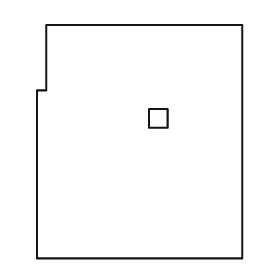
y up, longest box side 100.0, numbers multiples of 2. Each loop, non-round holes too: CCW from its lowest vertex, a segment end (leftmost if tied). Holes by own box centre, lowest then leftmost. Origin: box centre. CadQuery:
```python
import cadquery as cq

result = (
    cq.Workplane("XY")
    .moveTo(-44.0, -50.0)
    .lineTo(44.0, -50.0)
    .lineTo(44.0, 50.0)
    .lineTo(-40.0, 50.0)
    .lineTo(-40.0, 22.0)
    .lineTo(-44.0, 22.0)
    .close()
    .moveTo(4.0, 6.0)
    .lineTo(12.0, 6.0)
    .lineTo(12.0, 14.0)
    .lineTo(4.0, 14.0)
    .close()
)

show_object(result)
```